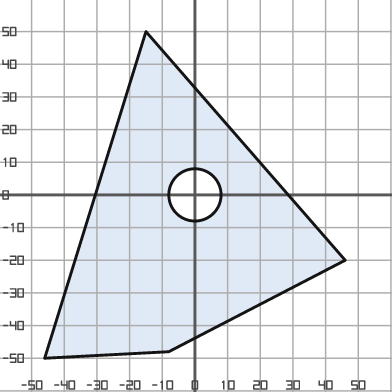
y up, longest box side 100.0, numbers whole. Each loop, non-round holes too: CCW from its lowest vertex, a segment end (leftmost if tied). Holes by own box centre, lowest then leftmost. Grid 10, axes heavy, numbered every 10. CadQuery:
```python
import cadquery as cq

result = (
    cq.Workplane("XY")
    .moveTo(-46.0, -50.0)
    .lineTo(-8.0, -48.0)
    .lineTo(46.0, -20.0)
    .lineTo(-15.0, 50.0)
    .close()
    .moveTo(0.0, 0.0)
    .circle(8.0)
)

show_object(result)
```